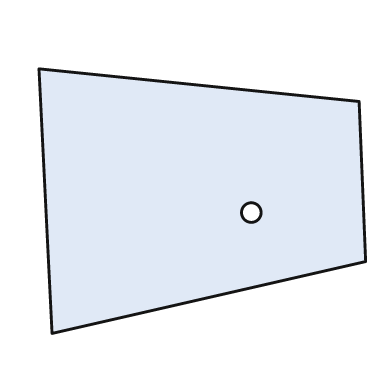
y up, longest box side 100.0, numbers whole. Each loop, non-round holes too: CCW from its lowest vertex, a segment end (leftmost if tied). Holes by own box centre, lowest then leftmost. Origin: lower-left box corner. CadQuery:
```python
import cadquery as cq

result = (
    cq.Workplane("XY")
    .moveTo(4.0, 0.0)
    .lineTo(100.0, 22.0)
    .lineTo(98.0, 71.0)
    .lineTo(0.0, 81.0)
    .close()
    .moveTo(65.0, 37.0)
    .circle(3.0)
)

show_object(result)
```